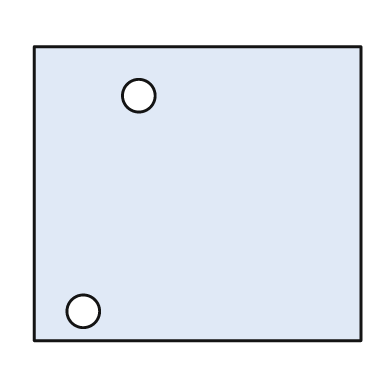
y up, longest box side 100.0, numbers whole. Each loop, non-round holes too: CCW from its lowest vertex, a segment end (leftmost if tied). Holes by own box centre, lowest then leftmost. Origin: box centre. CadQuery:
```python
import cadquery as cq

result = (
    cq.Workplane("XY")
    .moveTo(-50.0, -45.0)
    .lineTo(50.0, -45.0)
    .lineTo(50.0, 45.0)
    .lineTo(-50.0, 45.0)
    .close()
    .moveTo(-35.0, -36.0)
    .circle(5.0)
    .moveTo(-18.0, 30.0)
    .circle(5.0)
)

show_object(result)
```